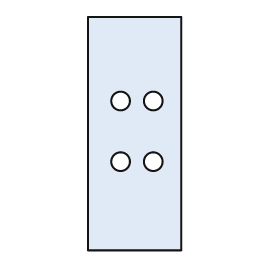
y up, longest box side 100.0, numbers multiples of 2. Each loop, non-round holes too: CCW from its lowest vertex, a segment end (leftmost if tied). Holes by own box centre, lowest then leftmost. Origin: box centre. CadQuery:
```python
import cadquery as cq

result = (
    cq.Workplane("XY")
    .moveTo(-20.0, -50.0)
    .lineTo(20.0, -50.0)
    .lineTo(20.0, 50.0)
    .lineTo(-20.0, 50.0)
    .close()
    .moveTo(-6.0, -12.0)
    .circle(4.0)
    .moveTo(8.0, -12.0)
    .circle(4.0)
    .moveTo(-6.0, 14.0)
    .circle(4.0)
    .moveTo(8.0, 14.0)
    .circle(4.0)
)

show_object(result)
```